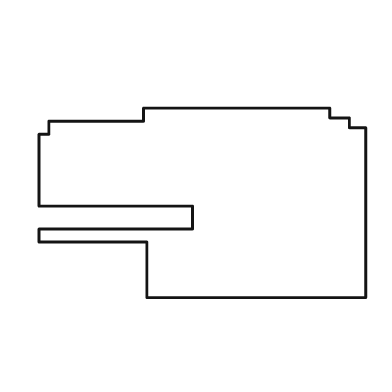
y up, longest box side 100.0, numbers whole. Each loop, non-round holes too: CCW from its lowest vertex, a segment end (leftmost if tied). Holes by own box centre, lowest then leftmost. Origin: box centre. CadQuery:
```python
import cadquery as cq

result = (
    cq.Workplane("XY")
    .moveTo(-17.0, -29.0)
    .lineTo(50.0, -29.0)
    .lineTo(50.0, 23.0)
    .lineTo(45.0, 23.0)
    .lineTo(45.0, 26.0)
    .lineTo(39.0, 26.0)
    .lineTo(39.0, 29.0)
    .lineTo(-18.0, 29.0)
    .lineTo(-18.0, 25.0)
    .lineTo(-47.0, 25.0)
    .lineTo(-47.0, 21.0)
    .lineTo(-50.0, 21.0)
    .lineTo(-50.0, -1.0)
    .lineTo(-3.0, -1.0)
    .lineTo(-3.0, -8.0)
    .lineTo(-50.0, -8.0)
    .lineTo(-50.0, -12.0)
    .lineTo(-17.0, -12.0)
    .close()
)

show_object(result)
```